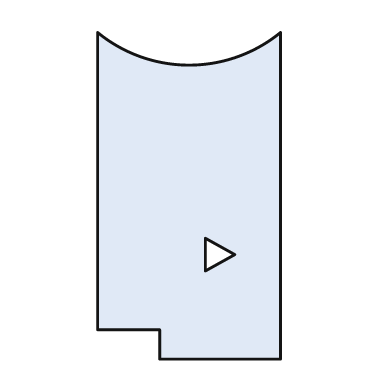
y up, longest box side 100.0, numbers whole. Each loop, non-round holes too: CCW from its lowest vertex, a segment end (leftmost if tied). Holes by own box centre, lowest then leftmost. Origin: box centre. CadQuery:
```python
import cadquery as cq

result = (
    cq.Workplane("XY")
    .moveTo(-9.0, -50.0)
    .lineTo(28.0, -50.0)
    .lineTo(28.0, 50.0)
    .threePointArc((0.0, 40.0), (-28.0, 50.0))
    .lineTo(-28.0, -41.0)
    .lineTo(-9.0, -41.0)
    .close()
    .moveTo(5.0, -23.0)
    .lineTo(14.0, -18.0)
    .lineTo(5.0, -13.0)
    .close()
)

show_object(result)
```